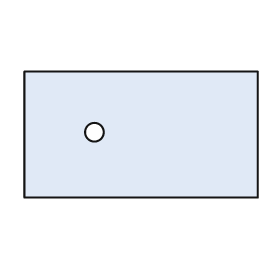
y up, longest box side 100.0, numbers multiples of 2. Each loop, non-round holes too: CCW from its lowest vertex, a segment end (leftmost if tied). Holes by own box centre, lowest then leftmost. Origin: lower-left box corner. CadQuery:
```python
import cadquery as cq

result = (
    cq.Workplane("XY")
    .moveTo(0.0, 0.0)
    .lineTo(100.0, 0.0)
    .lineTo(100.0, 54.0)
    .lineTo(0.0, 54.0)
    .close()
    .moveTo(30.0, 28.0)
    .circle(4.0)
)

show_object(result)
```